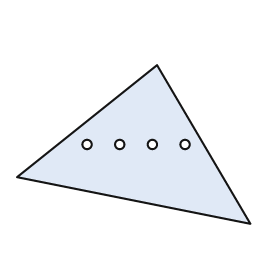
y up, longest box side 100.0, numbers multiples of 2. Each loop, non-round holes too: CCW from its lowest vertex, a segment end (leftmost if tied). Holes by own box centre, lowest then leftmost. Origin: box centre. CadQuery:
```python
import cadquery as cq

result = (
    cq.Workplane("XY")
    .moveTo(50.0, -34.0)
    .lineTo(10.0, 34.0)
    .lineTo(-50.0, -14.0)
    .close()
    .moveTo(-20.0, 0.0)
    .circle(2.0)
    .moveTo(-6.0, 0.0)
    .circle(2.0)
    .moveTo(8.0, 0.0)
    .circle(2.0)
    .moveTo(22.0, 0.0)
    .circle(2.0)
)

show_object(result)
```